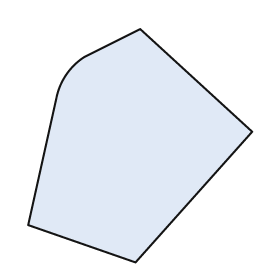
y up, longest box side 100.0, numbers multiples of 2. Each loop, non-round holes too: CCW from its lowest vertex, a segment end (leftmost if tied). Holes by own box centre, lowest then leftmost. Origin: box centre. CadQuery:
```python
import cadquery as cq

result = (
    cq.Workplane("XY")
    .moveTo(-2.0, -50.0)
    .lineTo(48.0, 6.0)
    .lineTo(0.0, 50.0)
    .lineTo(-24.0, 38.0)
    .threePointArc((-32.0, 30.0), (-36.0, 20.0))
    .lineTo(-48.0, -34.0)
    .close()
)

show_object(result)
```